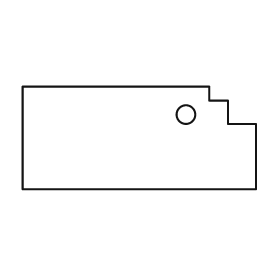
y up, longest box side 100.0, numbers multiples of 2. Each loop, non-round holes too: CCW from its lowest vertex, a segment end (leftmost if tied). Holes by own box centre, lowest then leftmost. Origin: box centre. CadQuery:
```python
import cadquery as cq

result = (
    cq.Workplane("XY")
    .moveTo(-50.0, -22.0)
    .lineTo(50.0, -22.0)
    .lineTo(50.0, 6.0)
    .lineTo(38.0, 6.0)
    .lineTo(38.0, 16.0)
    .lineTo(30.0, 16.0)
    .lineTo(30.0, 22.0)
    .lineTo(-50.0, 22.0)
    .close()
    .moveTo(20.0, 10.0)
    .circle(4.0)
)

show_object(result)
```